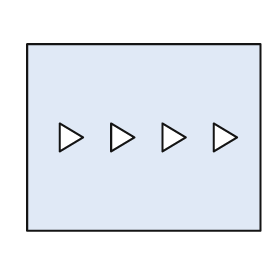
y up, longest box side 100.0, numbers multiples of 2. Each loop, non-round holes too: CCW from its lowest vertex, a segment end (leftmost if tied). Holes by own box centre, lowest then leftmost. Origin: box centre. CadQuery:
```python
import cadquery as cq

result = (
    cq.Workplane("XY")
    .moveTo(-50.0, -40.0)
    .lineTo(50.0, -40.0)
    .lineTo(50.0, 40.0)
    .lineTo(-50.0, 40.0)
    .close()
    .moveTo(-36.0, -6.0)
    .lineTo(-26.0, 0.0)
    .lineTo(-36.0, 6.0)
    .close()
    .moveTo(-14.0, -6.0)
    .lineTo(-4.0, 0.0)
    .lineTo(-14.0, 6.0)
    .close()
    .moveTo(8.0, -6.0)
    .lineTo(18.0, 0.0)
    .lineTo(8.0, 6.0)
    .close()
    .moveTo(30.0, -6.0)
    .lineTo(40.0, 0.0)
    .lineTo(30.0, 6.0)
    .close()
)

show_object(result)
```